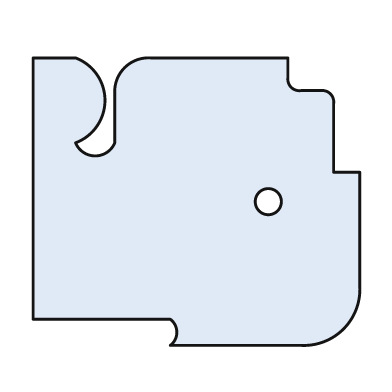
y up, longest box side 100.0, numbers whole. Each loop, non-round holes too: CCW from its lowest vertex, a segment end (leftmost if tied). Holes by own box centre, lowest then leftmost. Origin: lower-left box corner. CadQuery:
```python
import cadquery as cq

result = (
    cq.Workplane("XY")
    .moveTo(42.0, 0.0)
    .lineTo(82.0, 0.0)
    .threePointArc((95.0, 5.0), (100.0, 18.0))
    .lineTo(100.0, 53.0)
    .lineTo(92.0, 53.0)
    .lineTo(92.0, 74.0)
    .threePointArc((91.0, 77.0), (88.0, 78.0))
    .lineTo(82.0, 78.0)
    .threePointArc((79.0, 79.0), (78.0, 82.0))
    .lineTo(78.0, 88.0)
    .lineTo(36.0, 88.0)
    .threePointArc((28.0, 85.0), (25.0, 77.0))
    .lineTo(25.0, 62.0)
    .threePointArc((19.0, 58.0), (13.0, 62.0))
    .threePointArc((22.0, 75.0), (13.0, 88.0))
    .lineTo(0.0, 88.0)
    .lineTo(0.0, 8.0)
    .lineTo(42.0, 8.0)
    .threePointArc((44.0, 4.0), (42.0, 0.0))
    .close()
    .moveTo(72.0, 44.0)
    .circle(4.0)
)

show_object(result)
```